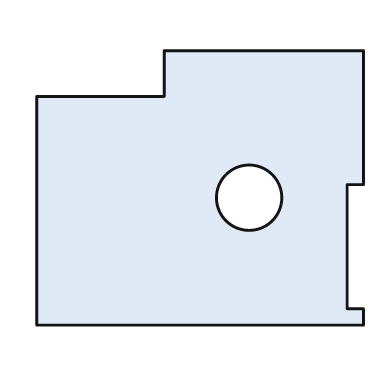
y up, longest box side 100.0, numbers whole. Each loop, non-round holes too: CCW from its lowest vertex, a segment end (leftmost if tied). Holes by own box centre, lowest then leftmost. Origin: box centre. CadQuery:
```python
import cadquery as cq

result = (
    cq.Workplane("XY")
    .moveTo(-50.0, -42.0)
    .lineTo(50.0, -42.0)
    .lineTo(50.0, -37.0)
    .lineTo(45.0, -37.0)
    .lineTo(45.0, 1.0)
    .lineTo(50.0, 1.0)
    .lineTo(50.0, 42.0)
    .lineTo(-11.0, 42.0)
    .lineTo(-11.0, 28.0)
    .lineTo(-50.0, 28.0)
    .close()
    .moveTo(15.0, -3.0)
    .circle(10.0)
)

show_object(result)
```